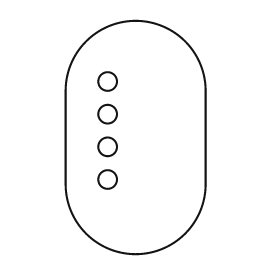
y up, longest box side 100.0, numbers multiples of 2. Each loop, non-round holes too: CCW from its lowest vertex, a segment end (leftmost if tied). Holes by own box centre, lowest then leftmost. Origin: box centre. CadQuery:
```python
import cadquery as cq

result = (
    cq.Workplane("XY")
    .moveTo(-30.0, -20.0)
    .threePointArc((0.0, -50.0), (30.0, -20.0))
    .lineTo(30.0, 20.0)
    .threePointArc((0.0, 50.0), (-30.0, 20.0))
    .close()
    .moveTo(-12.0, -18.0)
    .circle(4.0)
    .moveTo(-12.0, -4.0)
    .circle(4.0)
    .moveTo(-12.0, 10.0)
    .circle(4.0)
    .moveTo(-12.0, 24.0)
    .circle(4.0)
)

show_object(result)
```